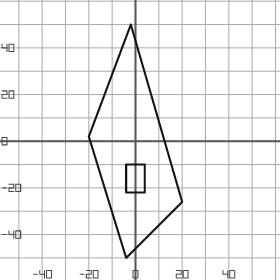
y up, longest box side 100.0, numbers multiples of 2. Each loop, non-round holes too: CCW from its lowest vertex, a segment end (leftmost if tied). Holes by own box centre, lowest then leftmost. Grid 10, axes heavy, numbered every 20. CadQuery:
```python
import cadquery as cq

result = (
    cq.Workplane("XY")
    .moveTo(-4.0, -50.0)
    .lineTo(20.0, -26.0)
    .lineTo(-2.0, 50.0)
    .lineTo(-20.0, 2.0)
    .close()
    .moveTo(-4.0, -22.0)
    .lineTo(4.0, -22.0)
    .lineTo(4.0, -10.0)
    .lineTo(-4.0, -10.0)
    .close()
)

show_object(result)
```